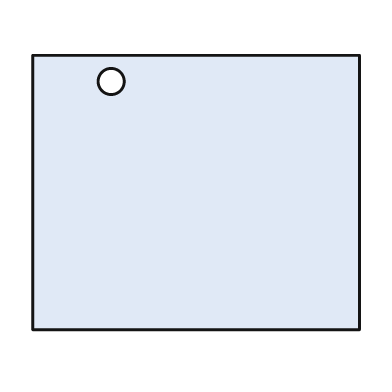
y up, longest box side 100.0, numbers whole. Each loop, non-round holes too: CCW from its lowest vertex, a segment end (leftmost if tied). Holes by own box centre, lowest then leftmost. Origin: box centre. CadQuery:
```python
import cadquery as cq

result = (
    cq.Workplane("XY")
    .moveTo(-50.0, -42.0)
    .lineTo(50.0, -42.0)
    .lineTo(50.0, 42.0)
    .lineTo(-50.0, 42.0)
    .close()
    .moveTo(-26.0, 34.0)
    .circle(4.0)
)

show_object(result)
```